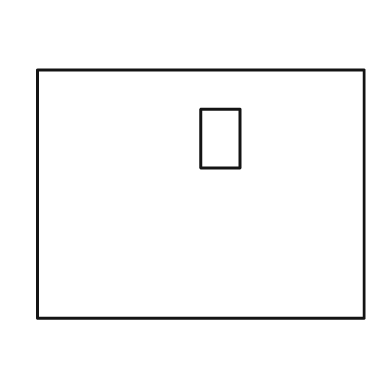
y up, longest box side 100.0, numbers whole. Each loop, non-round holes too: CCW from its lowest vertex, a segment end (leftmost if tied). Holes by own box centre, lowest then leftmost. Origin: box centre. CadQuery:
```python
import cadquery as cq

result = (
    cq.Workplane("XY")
    .moveTo(-50.0, -38.0)
    .lineTo(50.0, -38.0)
    .lineTo(50.0, 38.0)
    .lineTo(-50.0, 38.0)
    .close()
    .moveTo(0.0, 8.0)
    .lineTo(12.0, 8.0)
    .lineTo(12.0, 26.0)
    .lineTo(0.0, 26.0)
    .close()
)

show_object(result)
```